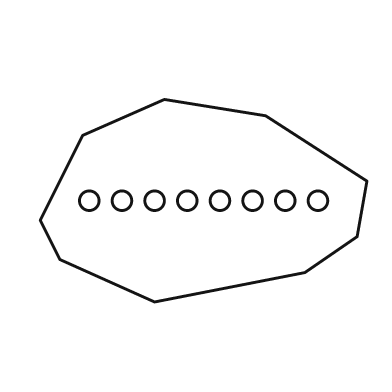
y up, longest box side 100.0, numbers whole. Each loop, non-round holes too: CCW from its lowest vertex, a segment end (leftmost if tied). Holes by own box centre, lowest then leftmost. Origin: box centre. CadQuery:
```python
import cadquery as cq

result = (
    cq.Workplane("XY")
    .moveTo(-15.0, -31.0)
    .lineTo(31.0, -22.0)
    .lineTo(47.0, -11.0)
    .lineTo(50.0, 6.0)
    .lineTo(19.0, 26.0)
    .lineTo(-12.0, 31.0)
    .lineTo(-37.0, 20.0)
    .lineTo(-50.0, -6.0)
    .lineTo(-44.0, -18.0)
    .close()
    .moveTo(-35.0, 0.0)
    .circle(3.0)
    .moveTo(-25.0, 0.0)
    .circle(3.0)
    .moveTo(-15.0, 0.0)
    .circle(3.0)
    .moveTo(-5.0, 0.0)
    .circle(3.0)
    .moveTo(5.0, 0.0)
    .circle(3.0)
    .moveTo(15.0, 0.0)
    .circle(3.0)
    .moveTo(25.0, 0.0)
    .circle(3.0)
    .moveTo(35.0, 0.0)
    .circle(3.0)
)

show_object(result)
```